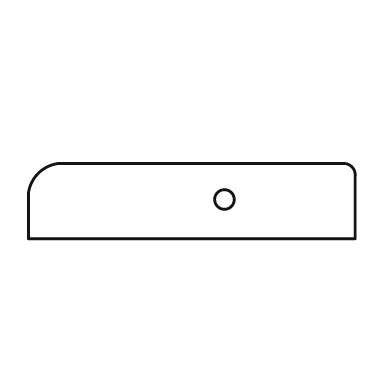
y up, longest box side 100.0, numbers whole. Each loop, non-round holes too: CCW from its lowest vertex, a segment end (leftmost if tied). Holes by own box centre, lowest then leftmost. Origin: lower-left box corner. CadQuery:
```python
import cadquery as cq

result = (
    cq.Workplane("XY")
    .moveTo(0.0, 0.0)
    .lineTo(100.0, 0.0)
    .lineTo(100.0, 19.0)
    .threePointArc((99.0, 22.0), (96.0, 23.0))
    .lineTo(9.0, 23.0)
    .threePointArc((3.0, 20.0), (0.0, 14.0))
    .close()
    .moveTo(60.0, 12.0)
    .circle(3.0)
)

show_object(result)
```